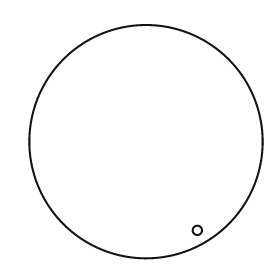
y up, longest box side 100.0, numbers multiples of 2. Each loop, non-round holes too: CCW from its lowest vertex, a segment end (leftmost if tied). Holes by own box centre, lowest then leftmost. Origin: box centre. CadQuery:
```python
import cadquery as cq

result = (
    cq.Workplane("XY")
    .moveTo(0.0, 0.0)
    .circle(50.0)
    .moveTo(22.0, -38.0)
    .circle(2.0)
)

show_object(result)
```